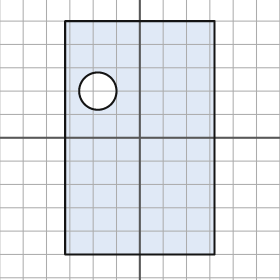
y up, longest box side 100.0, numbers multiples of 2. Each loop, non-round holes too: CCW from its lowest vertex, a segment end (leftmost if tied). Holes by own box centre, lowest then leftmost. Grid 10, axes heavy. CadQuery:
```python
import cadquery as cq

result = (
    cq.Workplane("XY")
    .moveTo(-32.0, -50.0)
    .lineTo(32.0, -50.0)
    .lineTo(32.0, 50.0)
    .lineTo(-32.0, 50.0)
    .close()
    .moveTo(-18.0, 20.0)
    .circle(8.0)
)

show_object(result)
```